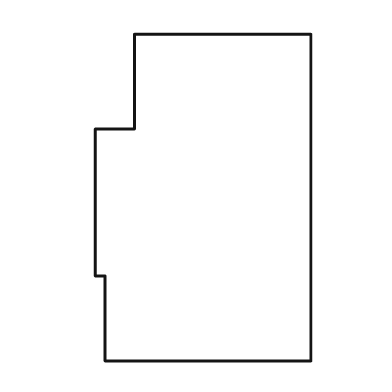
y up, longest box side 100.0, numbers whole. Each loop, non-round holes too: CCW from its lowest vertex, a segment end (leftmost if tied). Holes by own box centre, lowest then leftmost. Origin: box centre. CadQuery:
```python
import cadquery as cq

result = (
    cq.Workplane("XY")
    .moveTo(-30.0, -50.0)
    .lineTo(33.0, -50.0)
    .lineTo(33.0, 50.0)
    .lineTo(-21.0, 50.0)
    .lineTo(-21.0, 21.0)
    .lineTo(-33.0, 21.0)
    .lineTo(-33.0, -24.0)
    .lineTo(-30.0, -24.0)
    .close()
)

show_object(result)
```